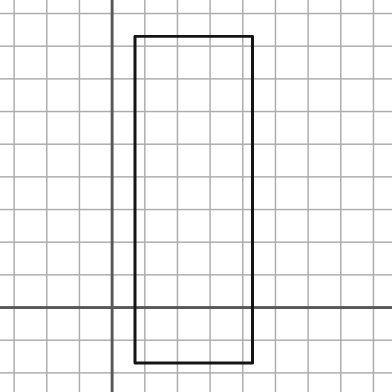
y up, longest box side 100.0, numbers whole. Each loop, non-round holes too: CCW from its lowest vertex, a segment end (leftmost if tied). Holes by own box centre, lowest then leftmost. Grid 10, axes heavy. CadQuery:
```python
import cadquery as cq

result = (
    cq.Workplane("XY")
    .moveTo(7.0, -17.0)
    .lineTo(43.0, -17.0)
    .lineTo(43.0, 83.0)
    .lineTo(7.0, 83.0)
    .close()
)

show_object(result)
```